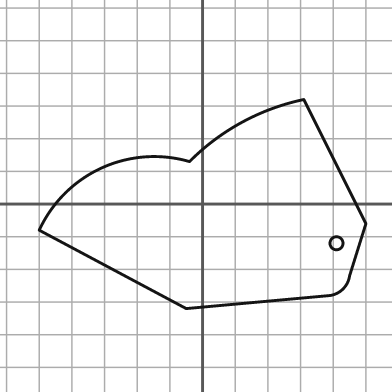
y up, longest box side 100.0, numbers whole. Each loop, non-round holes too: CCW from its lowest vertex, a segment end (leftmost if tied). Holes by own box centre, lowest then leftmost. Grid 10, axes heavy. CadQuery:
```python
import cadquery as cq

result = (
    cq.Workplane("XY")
    .moveTo(-5.0, -32.0)
    .lineTo(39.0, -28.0)
    .threePointArc((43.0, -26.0), (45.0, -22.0))
    .lineTo(50.0, -6.0)
    .lineTo(31.0, 32.0)
    .threePointArc((12.0, 25.0), (-4.0, 13.0))
    .threePointArc((-31.0, 11.0), (-50.0, -8.0))
    .close()
    .moveTo(41.0, -12.0)
    .circle(2.0)
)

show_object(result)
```